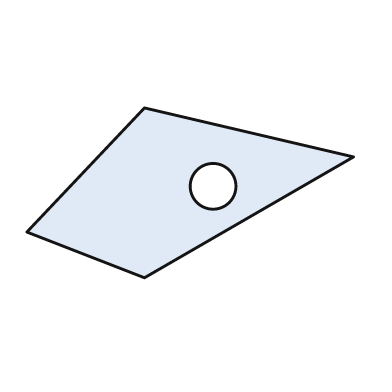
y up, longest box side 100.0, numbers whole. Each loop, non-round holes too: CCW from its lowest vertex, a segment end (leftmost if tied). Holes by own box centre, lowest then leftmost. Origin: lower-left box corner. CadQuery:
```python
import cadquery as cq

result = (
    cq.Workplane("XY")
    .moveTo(36.0, 0.0)
    .lineTo(100.0, 37.0)
    .lineTo(36.0, 52.0)
    .lineTo(0.0, 14.0)
    .close()
    .moveTo(57.0, 28.0)
    .circle(7.0)
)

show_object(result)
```